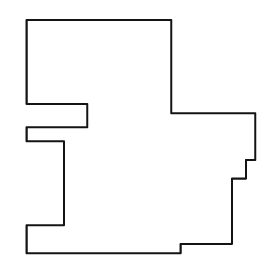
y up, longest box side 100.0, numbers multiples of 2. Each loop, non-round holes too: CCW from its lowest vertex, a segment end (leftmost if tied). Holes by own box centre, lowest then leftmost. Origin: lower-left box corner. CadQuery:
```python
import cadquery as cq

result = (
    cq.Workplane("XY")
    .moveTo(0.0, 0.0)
    .lineTo(66.0, 0.0)
    .lineTo(66.0, 4.0)
    .lineTo(88.0, 4.0)
    .lineTo(88.0, 32.0)
    .lineTo(94.0, 32.0)
    .lineTo(94.0, 40.0)
    .lineTo(98.0, 40.0)
    .lineTo(98.0, 60.0)
    .lineTo(62.0, 60.0)
    .lineTo(62.0, 100.0)
    .lineTo(0.0, 100.0)
    .lineTo(0.0, 64.0)
    .lineTo(26.0, 64.0)
    .lineTo(26.0, 54.0)
    .lineTo(0.0, 54.0)
    .lineTo(0.0, 48.0)
    .lineTo(16.0, 48.0)
    .lineTo(16.0, 12.0)
    .lineTo(0.0, 12.0)
    .close()
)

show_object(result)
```